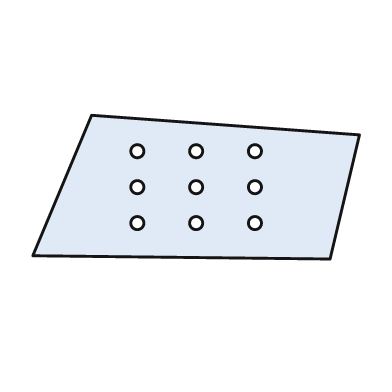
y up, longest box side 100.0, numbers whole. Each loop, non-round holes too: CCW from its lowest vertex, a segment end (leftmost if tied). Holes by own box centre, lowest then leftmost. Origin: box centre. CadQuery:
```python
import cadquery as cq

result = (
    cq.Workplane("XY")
    .moveTo(41.0, -22.0)
    .lineTo(50.0, 16.0)
    .lineTo(-32.0, 22.0)
    .lineTo(-50.0, -21.0)
    .close()
    .moveTo(-18.0, -11.0)
    .circle(2.0)
    .moveTo(0.0, -11.0)
    .circle(2.0)
    .moveTo(18.0, -11.0)
    .circle(2.0)
    .moveTo(-18.0, 0.0)
    .circle(2.0)
    .moveTo(0.0, 0.0)
    .circle(2.0)
    .moveTo(18.0, 0.0)
    .circle(2.0)
    .moveTo(-18.0, 11.0)
    .circle(2.0)
    .moveTo(0.0, 11.0)
    .circle(2.0)
    .moveTo(18.0, 11.0)
    .circle(2.0)
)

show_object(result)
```